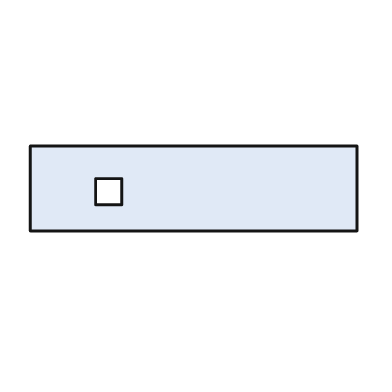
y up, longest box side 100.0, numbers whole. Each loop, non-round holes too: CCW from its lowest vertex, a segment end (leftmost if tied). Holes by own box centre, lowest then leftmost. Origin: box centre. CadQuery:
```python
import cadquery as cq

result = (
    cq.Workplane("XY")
    .moveTo(-50.0, -13.0)
    .lineTo(50.0, -13.0)
    .lineTo(50.0, 13.0)
    .lineTo(-50.0, 13.0)
    .close()
    .moveTo(-30.0, -5.0)
    .lineTo(-22.0, -5.0)
    .lineTo(-22.0, 3.0)
    .lineTo(-30.0, 3.0)
    .close()
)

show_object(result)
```